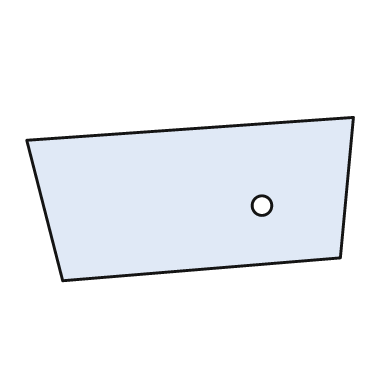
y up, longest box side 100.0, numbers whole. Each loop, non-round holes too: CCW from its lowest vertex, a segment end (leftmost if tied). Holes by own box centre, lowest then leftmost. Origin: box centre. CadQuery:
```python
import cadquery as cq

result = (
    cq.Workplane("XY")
    .moveTo(-39.0, -25.0)
    .lineTo(46.0, -18.0)
    .lineTo(50.0, 25.0)
    .lineTo(-50.0, 18.0)
    .close()
    .moveTo(22.0, -2.0)
    .circle(3.0)
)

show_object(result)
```